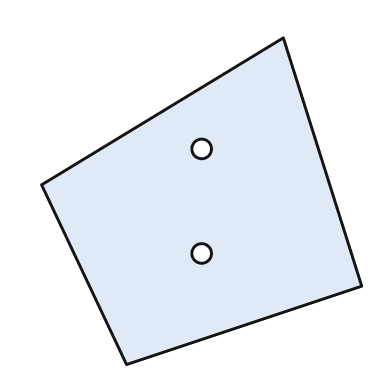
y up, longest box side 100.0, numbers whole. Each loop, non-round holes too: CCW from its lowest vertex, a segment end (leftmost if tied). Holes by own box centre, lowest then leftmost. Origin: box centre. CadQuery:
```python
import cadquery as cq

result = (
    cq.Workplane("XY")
    .moveTo(-23.0, -50.0)
    .lineTo(49.0, -26.0)
    .lineTo(25.0, 50.0)
    .lineTo(-49.0, 5.0)
    .close()
    .moveTo(0.0, -16.0)
    .circle(3.0)
    .moveTo(0.0, 16.0)
    .circle(3.0)
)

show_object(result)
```